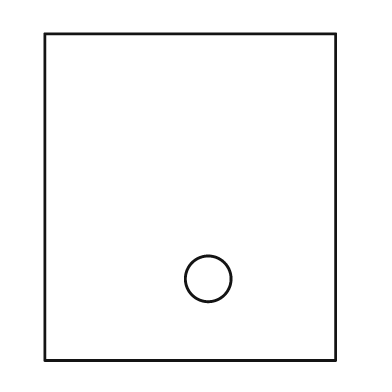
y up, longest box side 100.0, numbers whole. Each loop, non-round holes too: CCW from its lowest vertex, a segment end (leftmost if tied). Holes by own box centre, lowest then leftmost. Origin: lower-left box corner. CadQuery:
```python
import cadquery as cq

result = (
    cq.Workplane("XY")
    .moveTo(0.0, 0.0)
    .lineTo(89.0, 0.0)
    .lineTo(89.0, 100.0)
    .lineTo(0.0, 100.0)
    .close()
    .moveTo(50.0, 25.0)
    .circle(7.0)
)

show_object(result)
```